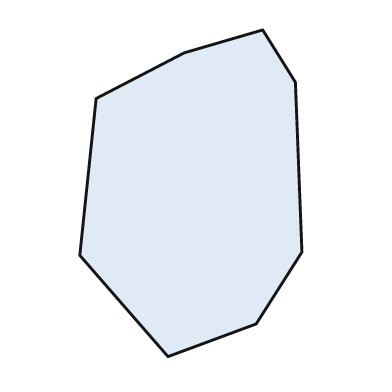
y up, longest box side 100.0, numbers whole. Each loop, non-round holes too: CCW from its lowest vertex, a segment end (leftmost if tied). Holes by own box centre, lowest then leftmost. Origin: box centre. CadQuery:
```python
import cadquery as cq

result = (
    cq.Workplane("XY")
    .moveTo(-7.0, -50.0)
    .lineTo(20.0, -40.0)
    .lineTo(34.0, -18.0)
    .lineTo(32.0, 34.0)
    .lineTo(22.0, 50.0)
    .lineTo(-2.0, 43.0)
    .lineTo(-29.0, 29.0)
    .lineTo(-34.0, -19.0)
    .close()
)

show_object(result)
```